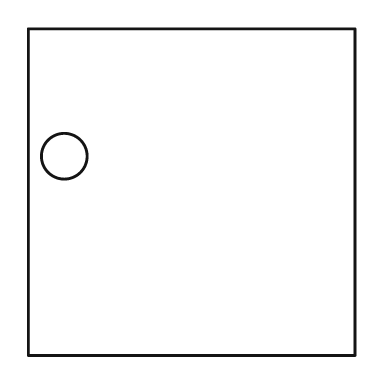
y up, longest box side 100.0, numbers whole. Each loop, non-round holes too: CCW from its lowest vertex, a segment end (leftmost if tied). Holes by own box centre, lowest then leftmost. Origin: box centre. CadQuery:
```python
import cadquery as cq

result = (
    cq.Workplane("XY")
    .moveTo(-50.0, -50.0)
    .lineTo(50.0, -50.0)
    .lineTo(50.0, 50.0)
    .lineTo(-50.0, 50.0)
    .close()
    .moveTo(-39.0, 11.0)
    .circle(7.0)
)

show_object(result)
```